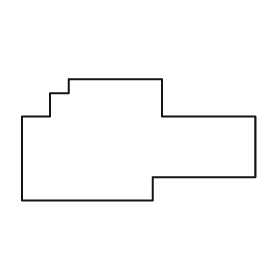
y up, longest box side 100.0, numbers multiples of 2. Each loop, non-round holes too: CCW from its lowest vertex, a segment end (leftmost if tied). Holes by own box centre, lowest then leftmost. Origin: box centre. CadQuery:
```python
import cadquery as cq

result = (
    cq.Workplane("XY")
    .moveTo(-50.0, -26.0)
    .lineTo(6.0, -26.0)
    .lineTo(6.0, -16.0)
    .lineTo(50.0, -16.0)
    .lineTo(50.0, 10.0)
    .lineTo(10.0, 10.0)
    .lineTo(10.0, 26.0)
    .lineTo(-30.0, 26.0)
    .lineTo(-30.0, 20.0)
    .lineTo(-38.0, 20.0)
    .lineTo(-38.0, 10.0)
    .lineTo(-50.0, 10.0)
    .close()
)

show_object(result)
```